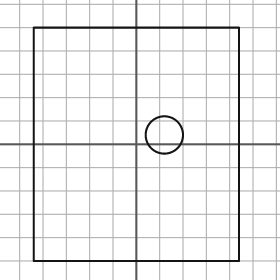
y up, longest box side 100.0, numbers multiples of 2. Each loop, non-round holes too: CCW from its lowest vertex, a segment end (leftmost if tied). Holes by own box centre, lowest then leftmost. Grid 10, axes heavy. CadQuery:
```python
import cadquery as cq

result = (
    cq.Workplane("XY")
    .moveTo(-44.0, -50.0)
    .lineTo(44.0, -50.0)
    .lineTo(44.0, 50.0)
    .lineTo(-44.0, 50.0)
    .close()
    .moveTo(12.0, 4.0)
    .circle(8.0)
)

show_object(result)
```